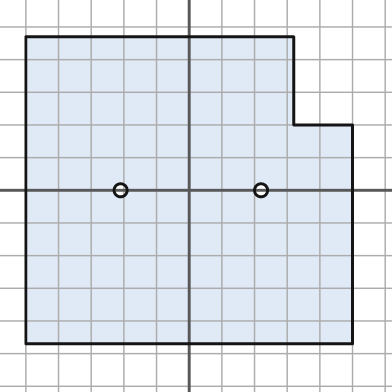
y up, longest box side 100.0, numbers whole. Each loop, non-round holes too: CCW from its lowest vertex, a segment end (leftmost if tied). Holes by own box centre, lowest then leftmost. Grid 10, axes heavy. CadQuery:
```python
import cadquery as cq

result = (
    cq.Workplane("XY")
    .moveTo(-50.0, -47.0)
    .lineTo(50.0, -47.0)
    .lineTo(50.0, 20.0)
    .lineTo(32.0, 20.0)
    .lineTo(32.0, 47.0)
    .lineTo(-50.0, 47.0)
    .close()
    .moveTo(-21.0, 0.0)
    .circle(2.0)
    .moveTo(22.0, 0.0)
    .circle(2.0)
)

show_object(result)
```